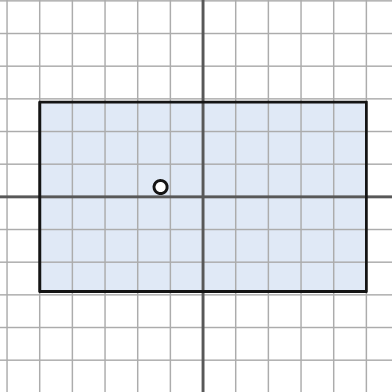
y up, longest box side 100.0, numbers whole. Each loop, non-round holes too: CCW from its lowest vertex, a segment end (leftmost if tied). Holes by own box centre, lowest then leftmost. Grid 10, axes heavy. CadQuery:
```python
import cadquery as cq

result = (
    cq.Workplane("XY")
    .moveTo(-50.0, -29.0)
    .lineTo(50.0, -29.0)
    .lineTo(50.0, 29.0)
    .lineTo(-50.0, 29.0)
    .close()
    .moveTo(-13.0, 3.0)
    .circle(2.0)
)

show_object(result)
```